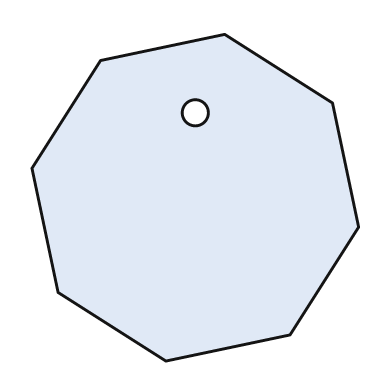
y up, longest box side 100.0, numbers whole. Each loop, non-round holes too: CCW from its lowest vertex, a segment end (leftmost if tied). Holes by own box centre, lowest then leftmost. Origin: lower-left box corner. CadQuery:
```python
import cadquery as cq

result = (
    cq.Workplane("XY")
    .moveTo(41.0, 0.0)
    .lineTo(79.0, 8.0)
    .lineTo(100.0, 41.0)
    .lineTo(92.0, 79.0)
    .lineTo(59.0, 100.0)
    .lineTo(21.0, 92.0)
    .lineTo(0.0, 59.0)
    .lineTo(8.0, 21.0)
    .close()
    .moveTo(50.0, 76.0)
    .circle(4.0)
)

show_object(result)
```